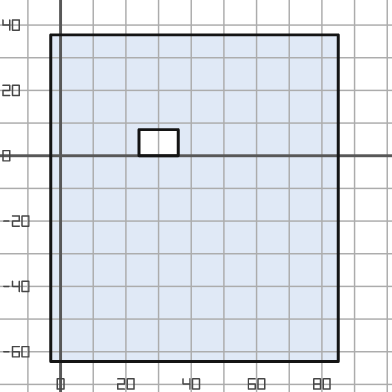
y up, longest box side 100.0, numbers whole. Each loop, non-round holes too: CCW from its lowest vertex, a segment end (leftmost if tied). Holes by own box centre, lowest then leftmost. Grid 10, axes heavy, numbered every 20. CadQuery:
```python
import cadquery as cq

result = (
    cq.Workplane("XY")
    .moveTo(-3.0, -63.0)
    .lineTo(85.0, -63.0)
    .lineTo(85.0, 37.0)
    .lineTo(-3.0, 37.0)
    .close()
    .moveTo(24.0, 0.0)
    .lineTo(36.0, 0.0)
    .lineTo(36.0, 8.0)
    .lineTo(24.0, 8.0)
    .close()
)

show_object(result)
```